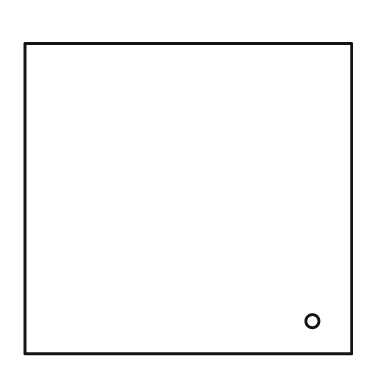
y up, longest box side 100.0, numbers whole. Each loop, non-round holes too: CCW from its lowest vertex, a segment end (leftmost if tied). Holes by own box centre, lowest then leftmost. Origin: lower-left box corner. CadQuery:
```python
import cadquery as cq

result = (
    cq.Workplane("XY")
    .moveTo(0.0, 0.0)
    .lineTo(100.0, 0.0)
    .lineTo(100.0, 95.0)
    .lineTo(0.0, 95.0)
    .close()
    .moveTo(88.0, 10.0)
    .circle(2.0)
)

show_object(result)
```